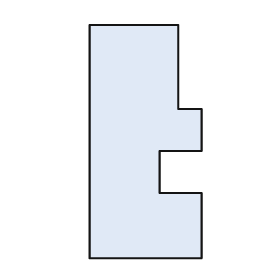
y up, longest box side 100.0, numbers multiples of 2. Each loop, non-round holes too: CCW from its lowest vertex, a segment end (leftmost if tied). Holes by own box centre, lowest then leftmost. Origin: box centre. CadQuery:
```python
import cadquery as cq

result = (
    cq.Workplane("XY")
    .moveTo(-24.0, -50.0)
    .lineTo(24.0, -50.0)
    .lineTo(24.0, -22.0)
    .lineTo(6.0, -22.0)
    .lineTo(6.0, -4.0)
    .lineTo(24.0, -4.0)
    .lineTo(24.0, 14.0)
    .lineTo(14.0, 14.0)
    .lineTo(14.0, 50.0)
    .lineTo(-24.0, 50.0)
    .close()
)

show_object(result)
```